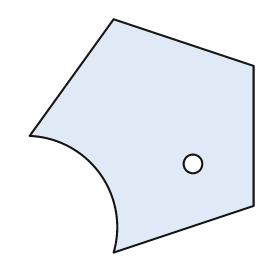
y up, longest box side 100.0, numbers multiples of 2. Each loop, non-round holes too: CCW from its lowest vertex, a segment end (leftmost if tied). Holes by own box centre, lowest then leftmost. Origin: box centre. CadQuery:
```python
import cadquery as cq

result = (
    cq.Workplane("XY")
    .moveTo(-12.0, -50.0)
    .lineTo(48.0, -30.0)
    .lineTo(48.0, 30.0)
    .lineTo(-12.0, 50.0)
    .lineTo(-48.0, 0.0)
    .threePointArc((-18.0, -16.0), (-12.0, -50.0))
    .close()
    .moveTo(22.0, -12.0)
    .circle(4.0)
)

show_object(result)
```